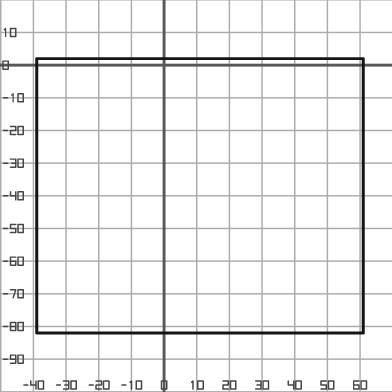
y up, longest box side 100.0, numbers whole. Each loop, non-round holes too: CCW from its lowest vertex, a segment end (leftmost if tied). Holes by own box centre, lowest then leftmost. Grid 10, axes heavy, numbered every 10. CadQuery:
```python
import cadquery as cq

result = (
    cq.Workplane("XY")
    .moveTo(-39.0, -82.0)
    .lineTo(61.0, -82.0)
    .lineTo(61.0, 2.0)
    .lineTo(-39.0, 2.0)
    .close()
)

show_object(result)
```